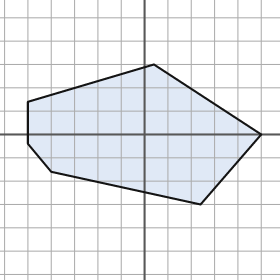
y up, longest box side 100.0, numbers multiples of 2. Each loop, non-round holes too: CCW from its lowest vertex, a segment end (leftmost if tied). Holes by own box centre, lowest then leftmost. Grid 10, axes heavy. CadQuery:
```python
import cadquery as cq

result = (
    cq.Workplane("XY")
    .moveTo(24.0, -30.0)
    .lineTo(50.0, 0.0)
    .lineTo(4.0, 30.0)
    .lineTo(-50.0, 14.0)
    .lineTo(-50.0, -4.0)
    .lineTo(-40.0, -16.0)
    .close()
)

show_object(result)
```